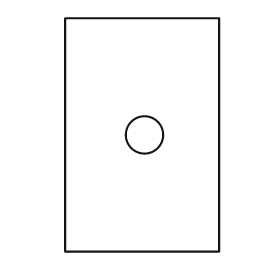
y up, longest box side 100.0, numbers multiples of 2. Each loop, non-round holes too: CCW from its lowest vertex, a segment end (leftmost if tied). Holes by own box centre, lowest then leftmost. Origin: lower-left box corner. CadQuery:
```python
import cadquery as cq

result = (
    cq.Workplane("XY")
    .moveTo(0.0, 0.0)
    .lineTo(66.0, 0.0)
    .lineTo(66.0, 100.0)
    .lineTo(0.0, 100.0)
    .close()
    .moveTo(34.0, 50.0)
    .circle(8.0)
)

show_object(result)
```